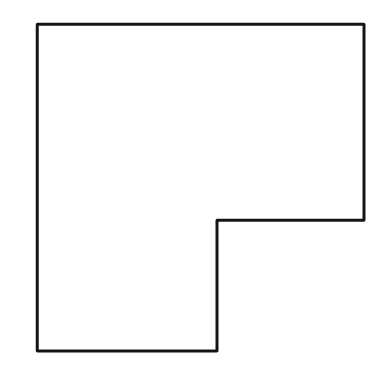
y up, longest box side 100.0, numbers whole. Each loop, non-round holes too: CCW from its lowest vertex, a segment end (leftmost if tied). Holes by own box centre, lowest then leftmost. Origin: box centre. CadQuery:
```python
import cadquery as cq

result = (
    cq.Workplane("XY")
    .moveTo(-50.0, -50.0)
    .lineTo(5.0, -50.0)
    .lineTo(5.0, -10.0)
    .lineTo(50.0, -10.0)
    .lineTo(50.0, 50.0)
    .lineTo(-50.0, 50.0)
    .close()
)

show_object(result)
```